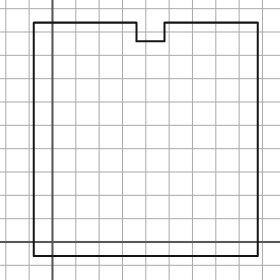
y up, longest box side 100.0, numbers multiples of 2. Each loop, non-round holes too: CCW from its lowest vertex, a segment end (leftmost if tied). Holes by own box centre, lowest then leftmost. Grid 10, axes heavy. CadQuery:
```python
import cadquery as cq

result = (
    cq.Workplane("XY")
    .moveTo(-8.0, -6.0)
    .lineTo(88.0, -6.0)
    .lineTo(88.0, 94.0)
    .lineTo(48.0, 94.0)
    .lineTo(48.0, 86.0)
    .lineTo(36.0, 86.0)
    .lineTo(36.0, 94.0)
    .lineTo(-8.0, 94.0)
    .close()
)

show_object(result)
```